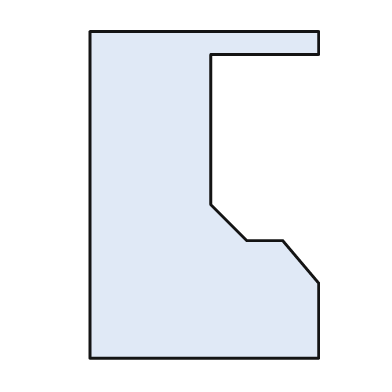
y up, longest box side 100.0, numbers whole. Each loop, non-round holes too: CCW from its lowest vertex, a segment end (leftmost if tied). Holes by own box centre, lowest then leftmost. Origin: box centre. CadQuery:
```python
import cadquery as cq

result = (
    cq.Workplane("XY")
    .moveTo(-35.0, -50.0)
    .lineTo(35.0, -50.0)
    .lineTo(35.0, -27.0)
    .lineTo(24.0, -14.0)
    .lineTo(13.0, -14.0)
    .lineTo(2.0, -3.0)
    .lineTo(2.0, 43.0)
    .lineTo(35.0, 43.0)
    .lineTo(35.0, 50.0)
    .lineTo(-35.0, 50.0)
    .close()
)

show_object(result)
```